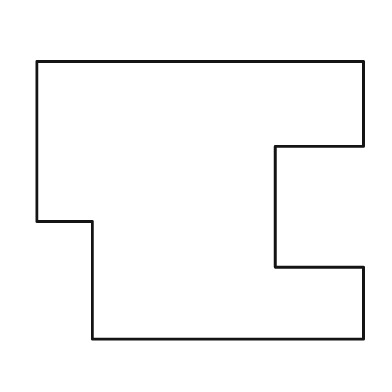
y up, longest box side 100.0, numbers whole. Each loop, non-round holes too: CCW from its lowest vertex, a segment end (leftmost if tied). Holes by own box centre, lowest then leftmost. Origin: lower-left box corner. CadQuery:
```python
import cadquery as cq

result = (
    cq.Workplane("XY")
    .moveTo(17.0, 0.0)
    .lineTo(100.0, 0.0)
    .lineTo(100.0, 22.0)
    .lineTo(73.0, 22.0)
    .lineTo(73.0, 59.0)
    .lineTo(100.0, 59.0)
    .lineTo(100.0, 85.0)
    .lineTo(0.0, 85.0)
    .lineTo(0.0, 36.0)
    .lineTo(17.0, 36.0)
    .close()
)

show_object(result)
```